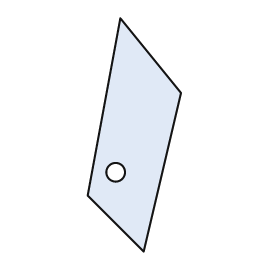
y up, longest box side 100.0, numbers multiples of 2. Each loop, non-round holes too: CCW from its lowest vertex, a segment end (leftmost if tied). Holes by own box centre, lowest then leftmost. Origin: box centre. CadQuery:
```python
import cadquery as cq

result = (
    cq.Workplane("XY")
    .moveTo(4.0, -50.0)
    .lineTo(20.0, 18.0)
    .lineTo(-6.0, 50.0)
    .lineTo(-20.0, -26.0)
    .close()
    .moveTo(-8.0, -16.0)
    .circle(4.0)
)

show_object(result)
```